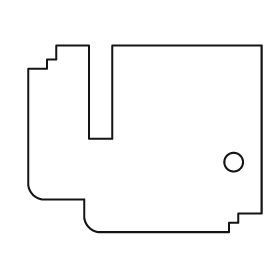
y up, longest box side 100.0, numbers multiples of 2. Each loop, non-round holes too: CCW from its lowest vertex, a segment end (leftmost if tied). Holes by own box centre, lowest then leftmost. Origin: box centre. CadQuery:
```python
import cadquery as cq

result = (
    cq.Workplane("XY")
    .moveTo(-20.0, -40.0)
    .lineTo(36.0, -40.0)
    .lineTo(36.0, -36.0)
    .lineTo(40.0, -36.0)
    .lineTo(40.0, -32.0)
    .lineTo(50.0, -32.0)
    .lineTo(50.0, 40.0)
    .lineTo(-14.0, 40.0)
    .lineTo(-14.0, 0.0)
    .lineTo(-24.0, 0.0)
    .lineTo(-24.0, 40.0)
    .lineTo(-38.0, 40.0)
    .lineTo(-38.0, 34.0)
    .lineTo(-42.0, 34.0)
    .lineTo(-42.0, 30.0)
    .lineTo(-50.0, 30.0)
    .lineTo(-50.0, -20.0)
    .threePointArc((-48.0, -24.0), (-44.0, -26.0))
    .lineTo(-26.0, -26.0)
    .lineTo(-26.0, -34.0)
    .threePointArc((-24.0, -38.0), (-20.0, -40.0))
    .close()
    .moveTo(38.0, -10.0)
    .circle(4.0)
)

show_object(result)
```